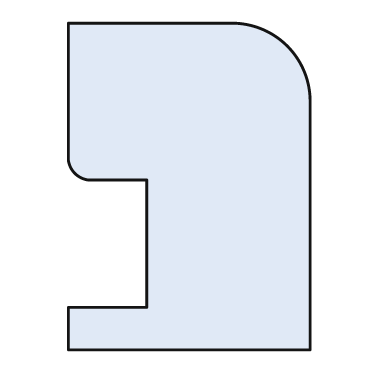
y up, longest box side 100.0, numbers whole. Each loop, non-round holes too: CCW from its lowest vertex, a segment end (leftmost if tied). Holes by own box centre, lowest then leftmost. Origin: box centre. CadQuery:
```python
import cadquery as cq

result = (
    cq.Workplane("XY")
    .moveTo(-37.0, -50.0)
    .lineTo(37.0, -50.0)
    .lineTo(37.0, 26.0)
    .threePointArc((30.0, 43.0), (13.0, 50.0))
    .lineTo(-37.0, 50.0)
    .lineTo(-37.0, 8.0)
    .threePointArc((-35.0, 4.0), (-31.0, 2.0))
    .lineTo(-13.0, 2.0)
    .lineTo(-13.0, -37.0)
    .lineTo(-37.0, -37.0)
    .close()
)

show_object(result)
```